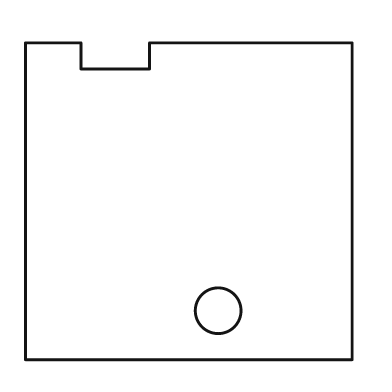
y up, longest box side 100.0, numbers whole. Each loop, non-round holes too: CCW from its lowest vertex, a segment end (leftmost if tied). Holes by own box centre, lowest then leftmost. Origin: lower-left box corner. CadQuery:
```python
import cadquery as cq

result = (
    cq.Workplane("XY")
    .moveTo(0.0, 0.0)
    .lineTo(100.0, 0.0)
    .lineTo(100.0, 97.0)
    .lineTo(38.0, 97.0)
    .lineTo(38.0, 89.0)
    .lineTo(17.0, 89.0)
    .lineTo(17.0, 97.0)
    .lineTo(0.0, 97.0)
    .close()
    .moveTo(59.0, 15.0)
    .circle(7.0)
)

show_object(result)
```